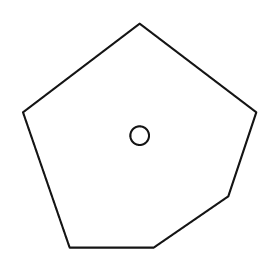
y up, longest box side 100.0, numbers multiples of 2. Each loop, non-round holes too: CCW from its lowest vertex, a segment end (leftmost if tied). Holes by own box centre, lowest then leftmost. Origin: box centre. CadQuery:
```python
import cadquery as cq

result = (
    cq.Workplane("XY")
    .moveTo(-30.0, -48.0)
    .lineTo(6.0, -48.0)
    .lineTo(38.0, -26.0)
    .lineTo(50.0, 10.0)
    .lineTo(0.0, 48.0)
    .lineTo(-50.0, 10.0)
    .close()
    .moveTo(0.0, 0.0)
    .circle(4.0)
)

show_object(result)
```